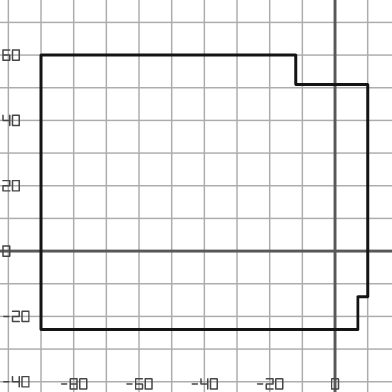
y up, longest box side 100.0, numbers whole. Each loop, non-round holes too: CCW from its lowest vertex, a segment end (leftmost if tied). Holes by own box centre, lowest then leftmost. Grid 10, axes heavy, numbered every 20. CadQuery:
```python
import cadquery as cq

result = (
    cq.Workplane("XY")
    .moveTo(-90.0, -24.0)
    .lineTo(7.0, -24.0)
    .lineTo(7.0, -14.0)
    .lineTo(10.0, -14.0)
    .lineTo(10.0, 51.0)
    .lineTo(-12.0, 51.0)
    .lineTo(-12.0, 60.0)
    .lineTo(-90.0, 60.0)
    .close()
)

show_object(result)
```